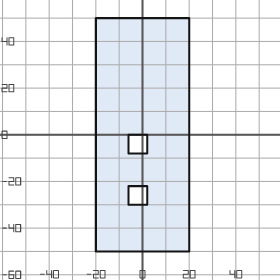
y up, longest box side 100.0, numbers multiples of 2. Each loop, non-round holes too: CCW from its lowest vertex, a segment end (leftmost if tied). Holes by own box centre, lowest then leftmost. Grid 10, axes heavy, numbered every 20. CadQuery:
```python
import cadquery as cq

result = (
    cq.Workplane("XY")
    .moveTo(-20.0, -50.0)
    .lineTo(20.0, -50.0)
    .lineTo(20.0, 50.0)
    .lineTo(-20.0, 50.0)
    .close()
    .moveTo(-6.0, -30.0)
    .lineTo(2.0, -30.0)
    .lineTo(2.0, -22.0)
    .lineTo(-6.0, -22.0)
    .close()
    .moveTo(-6.0, -8.0)
    .lineTo(2.0, -8.0)
    .lineTo(2.0, 0.0)
    .lineTo(-6.0, 0.0)
    .close()
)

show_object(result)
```